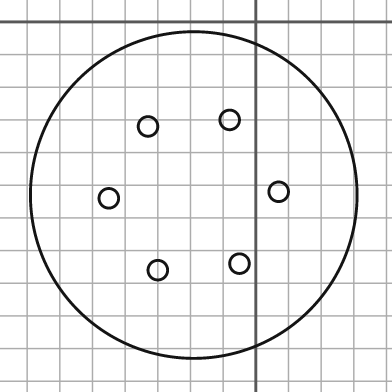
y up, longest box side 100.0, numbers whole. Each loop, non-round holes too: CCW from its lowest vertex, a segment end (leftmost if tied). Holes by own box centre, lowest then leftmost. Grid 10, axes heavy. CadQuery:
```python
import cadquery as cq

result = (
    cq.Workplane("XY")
    .moveTo(-19.0, -53.0)
    .circle(50.0)
    .moveTo(-30.0, -76.0)
    .circle(3.0)
    .moveTo(-5.0, -74.0)
    .circle(3.0)
    .moveTo(-45.0, -54.0)
    .circle(3.0)
    .moveTo(7.0, -52.0)
    .circle(3.0)
    .moveTo(-33.0, -32.0)
    .circle(3.0)
    .moveTo(-8.0, -30.0)
    .circle(3.0)
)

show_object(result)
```